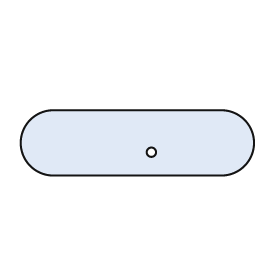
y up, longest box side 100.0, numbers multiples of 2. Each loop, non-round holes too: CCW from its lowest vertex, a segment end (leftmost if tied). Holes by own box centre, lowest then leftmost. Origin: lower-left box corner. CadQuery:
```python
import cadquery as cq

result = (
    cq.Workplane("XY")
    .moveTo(14.0, 0.0)
    .lineTo(86.0, 0.0)
    .threePointArc((100.0, 14.0), (86.0, 28.0))
    .lineTo(14.0, 28.0)
    .threePointArc((0.0, 14.0), (14.0, 0.0))
    .close()
    .moveTo(56.0, 10.0)
    .circle(2.0)
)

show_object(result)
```